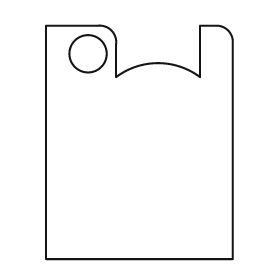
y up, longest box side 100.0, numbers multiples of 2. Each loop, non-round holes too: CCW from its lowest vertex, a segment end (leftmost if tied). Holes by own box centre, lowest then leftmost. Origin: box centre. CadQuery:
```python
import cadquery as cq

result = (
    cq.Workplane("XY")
    .moveTo(-40.0, -50.0)
    .lineTo(40.0, -50.0)
    .lineTo(40.0, 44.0)
    .threePointArc((38.0, 48.0), (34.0, 50.0))
    .lineTo(26.0, 50.0)
    .lineTo(26.0, 28.0)
    .threePointArc((8.0, 34.0), (-10.0, 28.0))
    .lineTo(-10.0, 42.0)
    .threePointArc((-12.0, 48.0), (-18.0, 50.0))
    .lineTo(-40.0, 50.0)
    .close()
    .moveTo(-22.0, 38.0)
    .circle(8.0)
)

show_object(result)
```